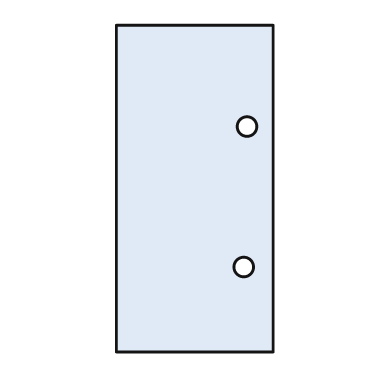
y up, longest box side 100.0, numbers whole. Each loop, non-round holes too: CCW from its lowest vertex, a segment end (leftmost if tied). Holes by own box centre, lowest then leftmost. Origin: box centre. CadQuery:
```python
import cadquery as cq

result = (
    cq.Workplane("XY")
    .moveTo(-24.0, -50.0)
    .lineTo(24.0, -50.0)
    .lineTo(24.0, 50.0)
    .lineTo(-24.0, 50.0)
    .close()
    .moveTo(15.0, -24.0)
    .circle(3.0)
    .moveTo(16.0, 19.0)
    .circle(3.0)
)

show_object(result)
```